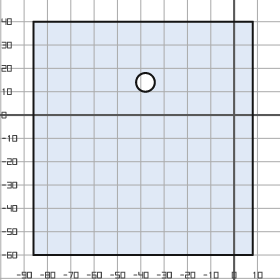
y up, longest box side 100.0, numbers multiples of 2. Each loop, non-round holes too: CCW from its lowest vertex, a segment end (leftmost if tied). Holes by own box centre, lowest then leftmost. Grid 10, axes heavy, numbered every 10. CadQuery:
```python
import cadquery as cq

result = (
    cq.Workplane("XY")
    .moveTo(-86.0, -60.0)
    .lineTo(8.0, -60.0)
    .lineTo(8.0, 40.0)
    .lineTo(-86.0, 40.0)
    .close()
    .moveTo(-38.0, 14.0)
    .circle(4.0)
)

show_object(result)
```